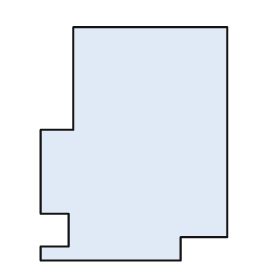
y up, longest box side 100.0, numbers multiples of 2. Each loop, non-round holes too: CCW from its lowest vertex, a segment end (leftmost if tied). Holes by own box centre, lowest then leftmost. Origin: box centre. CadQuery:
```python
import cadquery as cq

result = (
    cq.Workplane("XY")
    .moveTo(-40.0, -50.0)
    .lineTo(20.0, -50.0)
    .lineTo(20.0, -40.0)
    .lineTo(40.0, -40.0)
    .lineTo(40.0, 50.0)
    .lineTo(-26.0, 50.0)
    .lineTo(-26.0, 6.0)
    .lineTo(-40.0, 6.0)
    .lineTo(-40.0, -30.0)
    .lineTo(-28.0, -30.0)
    .lineTo(-28.0, -44.0)
    .lineTo(-40.0, -44.0)
    .close()
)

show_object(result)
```